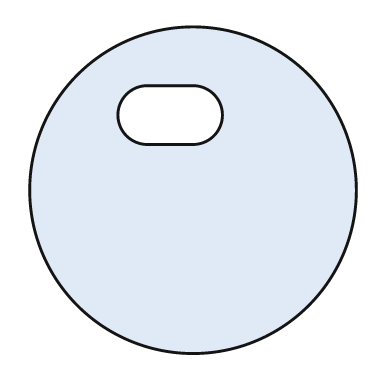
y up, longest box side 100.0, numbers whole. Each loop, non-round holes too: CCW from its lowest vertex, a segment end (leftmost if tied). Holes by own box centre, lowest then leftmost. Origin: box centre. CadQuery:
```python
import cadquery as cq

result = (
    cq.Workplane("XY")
    .moveTo(0.0, 0.0)
    .circle(50.0)
    .moveTo(-14.0, 14.0)
    .lineTo(0.0, 14.0)
    .threePointArc((9.0, 23.0), (0.0, 32.0))
    .lineTo(-14.0, 32.0)
    .threePointArc((-23.0, 23.0), (-14.0, 14.0))
    .close()
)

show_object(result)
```